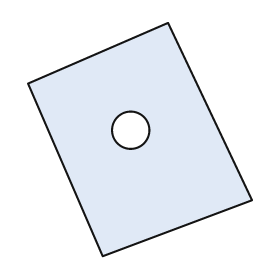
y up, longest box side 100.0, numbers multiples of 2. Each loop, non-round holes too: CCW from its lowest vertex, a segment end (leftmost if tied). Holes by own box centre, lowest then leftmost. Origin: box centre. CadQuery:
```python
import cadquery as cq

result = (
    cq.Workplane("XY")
    .moveTo(-16.0, -50.0)
    .lineTo(48.0, -26.0)
    .lineTo(12.0, 50.0)
    .lineTo(-48.0, 24.0)
    .close()
    .moveTo(-4.0, 4.0)
    .circle(8.0)
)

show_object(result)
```